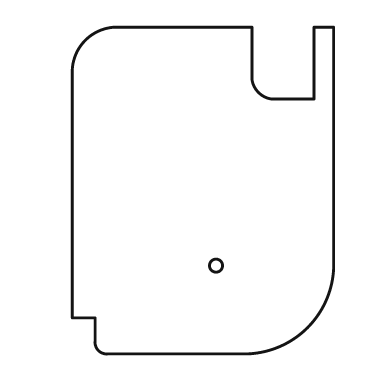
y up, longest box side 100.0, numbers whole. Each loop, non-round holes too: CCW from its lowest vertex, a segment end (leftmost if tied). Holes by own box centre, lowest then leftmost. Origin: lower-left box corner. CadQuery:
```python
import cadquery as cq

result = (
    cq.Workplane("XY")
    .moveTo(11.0, 0.0)
    .lineTo(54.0, 0.0)
    .threePointArc((72.0, 8.0), (80.0, 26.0))
    .lineTo(80.0, 100.0)
    .lineTo(74.0, 100.0)
    .lineTo(74.0, 78.0)
    .lineTo(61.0, 78.0)
    .threePointArc((57.0, 80.0), (55.0, 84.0))
    .lineTo(55.0, 100.0)
    .lineTo(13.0, 100.0)
    .threePointArc((4.0, 96.0), (0.0, 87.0))
    .lineTo(0.0, 11.0)
    .lineTo(7.0, 11.0)
    .lineTo(7.0, 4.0)
    .threePointArc((8.0, 1.0), (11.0, 0.0))
    .close()
    .moveTo(44.0, 27.0)
    .circle(2.0)
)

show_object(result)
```